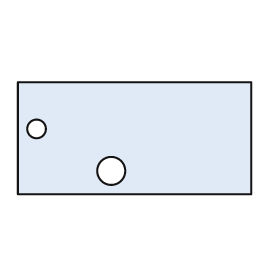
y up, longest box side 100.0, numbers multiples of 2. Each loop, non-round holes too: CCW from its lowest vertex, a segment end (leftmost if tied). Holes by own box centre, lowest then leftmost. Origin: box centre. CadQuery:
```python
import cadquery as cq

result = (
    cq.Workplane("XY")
    .moveTo(-50.0, -24.0)
    .lineTo(50.0, -24.0)
    .lineTo(50.0, 24.0)
    .lineTo(-50.0, 24.0)
    .close()
    .moveTo(-10.0, -14.0)
    .circle(6.0)
    .moveTo(-42.0, 4.0)
    .circle(4.0)
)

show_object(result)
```